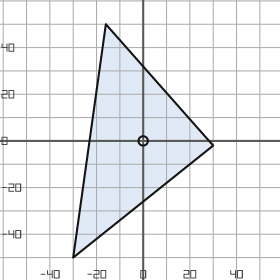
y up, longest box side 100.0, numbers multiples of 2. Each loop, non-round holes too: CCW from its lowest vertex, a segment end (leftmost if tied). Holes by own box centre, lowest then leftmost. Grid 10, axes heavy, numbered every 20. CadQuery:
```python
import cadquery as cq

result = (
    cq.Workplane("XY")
    .moveTo(-30.0, -50.0)
    .lineTo(30.0, -2.0)
    .lineTo(-16.0, 50.0)
    .close()
    .moveTo(0.0, 0.0)
    .circle(2.0)
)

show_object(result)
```